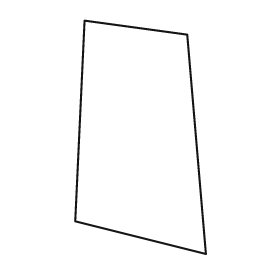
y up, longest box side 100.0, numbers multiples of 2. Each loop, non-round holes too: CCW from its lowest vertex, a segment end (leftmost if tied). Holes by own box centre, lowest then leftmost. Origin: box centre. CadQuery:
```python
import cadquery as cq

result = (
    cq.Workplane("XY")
    .moveTo(28.0, -50.0)
    .lineTo(20.0, 44.0)
    .lineTo(-24.0, 50.0)
    .lineTo(-28.0, -36.0)
    .close()
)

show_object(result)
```